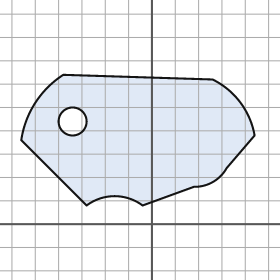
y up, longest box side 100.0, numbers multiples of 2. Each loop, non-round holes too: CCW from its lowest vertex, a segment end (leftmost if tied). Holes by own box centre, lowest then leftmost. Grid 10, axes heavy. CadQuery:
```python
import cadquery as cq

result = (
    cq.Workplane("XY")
    .moveTo(-28.0, 8.0)
    .threePointArc((-16.0, 12.0), (-4.0, 8.0))
    .lineTo(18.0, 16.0)
    .threePointArc((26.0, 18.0), (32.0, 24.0))
    .lineTo(44.0, 38.0)
    .threePointArc((38.0, 52.0), (26.0, 62.0))
    .lineTo(-38.0, 64.0)
    .threePointArc((-50.0, 52.0), (-56.0, 36.0))
    .close()
    .moveTo(-34.0, 44.0)
    .circle(6.0)
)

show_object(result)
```